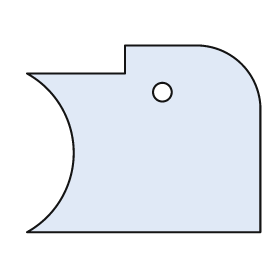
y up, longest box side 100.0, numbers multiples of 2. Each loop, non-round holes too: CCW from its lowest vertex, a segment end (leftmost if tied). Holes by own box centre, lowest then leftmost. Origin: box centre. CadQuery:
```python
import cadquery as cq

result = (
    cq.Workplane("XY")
    .moveTo(-50.0, -40.0)
    .lineTo(50.0, -40.0)
    .lineTo(50.0, 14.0)
    .threePointArc((42.0, 32.0), (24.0, 40.0))
    .lineTo(-8.0, 40.0)
    .lineTo(-8.0, 28.0)
    .lineTo(-50.0, 28.0)
    .threePointArc((-30.0, -6.0), (-50.0, -40.0))
    .close()
    .moveTo(8.0, 20.0)
    .circle(4.0)
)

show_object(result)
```